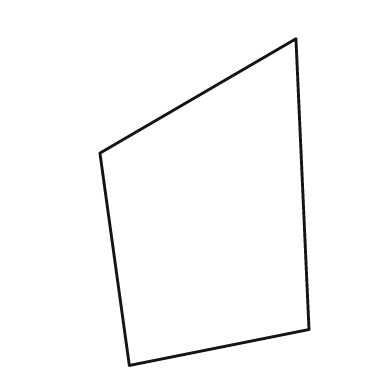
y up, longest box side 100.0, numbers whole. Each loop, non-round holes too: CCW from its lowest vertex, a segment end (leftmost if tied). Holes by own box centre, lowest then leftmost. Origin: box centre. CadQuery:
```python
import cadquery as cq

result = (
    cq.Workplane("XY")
    .moveTo(-23.0, -50.0)
    .lineTo(32.0, -39.0)
    .lineTo(28.0, 50.0)
    .lineTo(-32.0, 15.0)
    .close()
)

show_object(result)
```